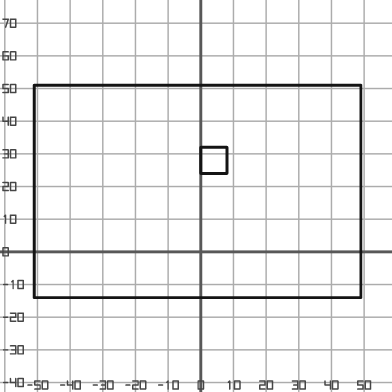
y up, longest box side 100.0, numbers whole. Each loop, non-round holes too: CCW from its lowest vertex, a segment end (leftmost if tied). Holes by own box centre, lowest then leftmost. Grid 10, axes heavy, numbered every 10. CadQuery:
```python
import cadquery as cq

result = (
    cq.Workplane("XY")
    .moveTo(-51.0, -14.0)
    .lineTo(49.0, -14.0)
    .lineTo(49.0, 51.0)
    .lineTo(-51.0, 51.0)
    .close()
    .moveTo(0.0, 24.0)
    .lineTo(8.0, 24.0)
    .lineTo(8.0, 32.0)
    .lineTo(0.0, 32.0)
    .close()
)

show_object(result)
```